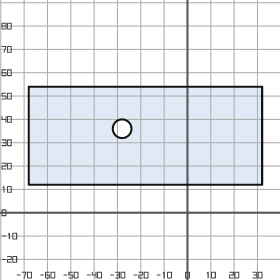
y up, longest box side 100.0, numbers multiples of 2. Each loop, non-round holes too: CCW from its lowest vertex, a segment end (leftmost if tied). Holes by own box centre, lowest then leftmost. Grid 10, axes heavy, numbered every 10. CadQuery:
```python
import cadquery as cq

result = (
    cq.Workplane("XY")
    .moveTo(-68.0, 12.0)
    .lineTo(32.0, 12.0)
    .lineTo(32.0, 54.0)
    .lineTo(-68.0, 54.0)
    .close()
    .moveTo(-28.0, 36.0)
    .circle(4.0)
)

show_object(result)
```